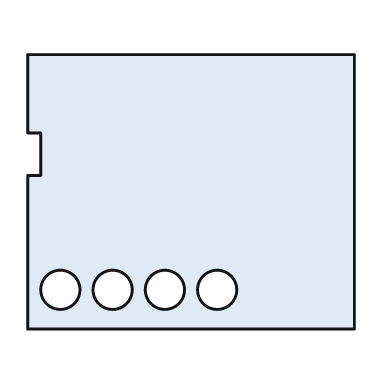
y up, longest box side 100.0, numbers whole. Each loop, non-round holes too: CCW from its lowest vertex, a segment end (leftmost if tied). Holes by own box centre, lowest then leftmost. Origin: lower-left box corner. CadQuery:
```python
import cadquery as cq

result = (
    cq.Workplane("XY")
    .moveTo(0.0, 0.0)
    .lineTo(100.0, 0.0)
    .lineTo(100.0, 84.0)
    .lineTo(0.0, 84.0)
    .lineTo(0.0, 60.0)
    .lineTo(4.0, 60.0)
    .lineTo(4.0, 47.0)
    .lineTo(0.0, 47.0)
    .close()
    .moveTo(10.0, 12.0)
    .circle(6.0)
    .moveTo(26.0, 12.0)
    .circle(6.0)
    .moveTo(42.0, 12.0)
    .circle(6.0)
    .moveTo(58.0, 12.0)
    .circle(6.0)
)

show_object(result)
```